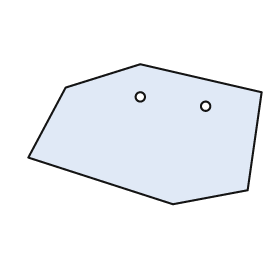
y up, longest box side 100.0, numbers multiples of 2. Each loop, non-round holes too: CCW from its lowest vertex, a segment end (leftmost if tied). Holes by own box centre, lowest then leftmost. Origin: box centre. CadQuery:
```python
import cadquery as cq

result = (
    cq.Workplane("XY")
    .moveTo(12.0, -30.0)
    .lineTo(44.0, -24.0)
    .lineTo(50.0, 18.0)
    .lineTo(-2.0, 30.0)
    .lineTo(-34.0, 20.0)
    .lineTo(-50.0, -10.0)
    .close()
    .moveTo(26.0, 12.0)
    .circle(2.0)
    .moveTo(-2.0, 16.0)
    .circle(2.0)
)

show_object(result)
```